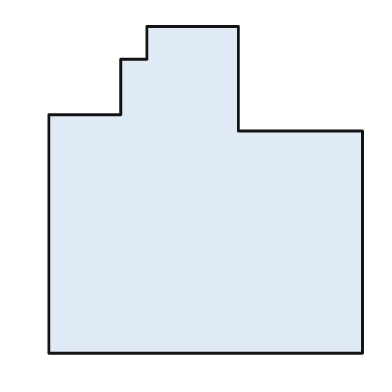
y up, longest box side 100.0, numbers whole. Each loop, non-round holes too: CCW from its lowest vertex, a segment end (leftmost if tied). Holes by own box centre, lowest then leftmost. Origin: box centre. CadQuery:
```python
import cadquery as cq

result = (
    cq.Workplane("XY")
    .moveTo(-48.0, -50.0)
    .lineTo(48.0, -50.0)
    .lineTo(48.0, 18.0)
    .lineTo(10.0, 18.0)
    .lineTo(10.0, 50.0)
    .lineTo(-18.0, 50.0)
    .lineTo(-18.0, 40.0)
    .lineTo(-26.0, 40.0)
    .lineTo(-26.0, 23.0)
    .lineTo(-48.0, 23.0)
    .close()
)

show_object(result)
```